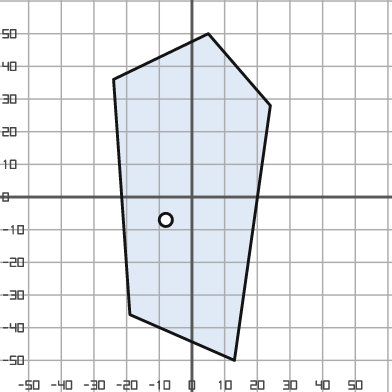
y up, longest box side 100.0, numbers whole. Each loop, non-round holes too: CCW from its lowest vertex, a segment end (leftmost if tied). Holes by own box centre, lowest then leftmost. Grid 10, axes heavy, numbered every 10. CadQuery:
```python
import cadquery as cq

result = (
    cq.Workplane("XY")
    .moveTo(13.0, -50.0)
    .lineTo(24.0, 28.0)
    .lineTo(5.0, 50.0)
    .lineTo(-24.0, 36.0)
    .lineTo(-19.0, -36.0)
    .close()
    .moveTo(-8.0, -7.0)
    .circle(2.0)
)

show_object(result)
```